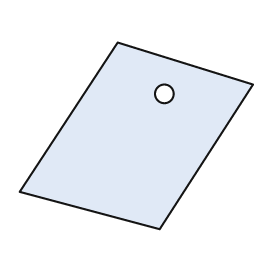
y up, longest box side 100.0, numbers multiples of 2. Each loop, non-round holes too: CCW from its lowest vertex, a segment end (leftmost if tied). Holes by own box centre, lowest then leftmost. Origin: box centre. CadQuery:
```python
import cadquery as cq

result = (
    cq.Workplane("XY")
    .moveTo(10.0, -40.0)
    .lineTo(50.0, 22.0)
    .lineTo(-8.0, 40.0)
    .lineTo(-50.0, -24.0)
    .close()
    .moveTo(12.0, 18.0)
    .circle(4.0)
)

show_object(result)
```